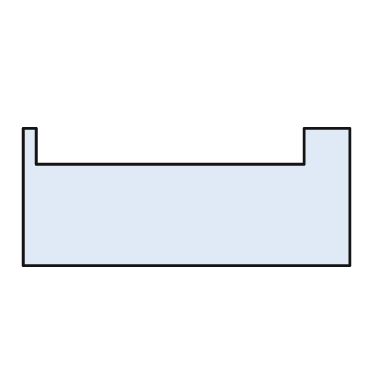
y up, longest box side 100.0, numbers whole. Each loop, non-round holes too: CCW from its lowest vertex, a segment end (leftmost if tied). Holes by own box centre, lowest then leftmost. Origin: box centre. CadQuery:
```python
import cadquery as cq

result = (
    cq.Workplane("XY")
    .moveTo(-50.0, -21.0)
    .lineTo(50.0, -21.0)
    .lineTo(50.0, 21.0)
    .lineTo(36.0, 21.0)
    .lineTo(36.0, 10.0)
    .lineTo(-46.0, 10.0)
    .lineTo(-46.0, 21.0)
    .lineTo(-50.0, 21.0)
    .close()
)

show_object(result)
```